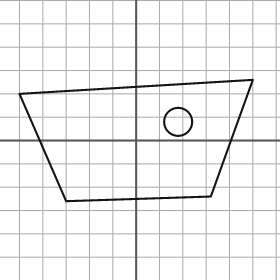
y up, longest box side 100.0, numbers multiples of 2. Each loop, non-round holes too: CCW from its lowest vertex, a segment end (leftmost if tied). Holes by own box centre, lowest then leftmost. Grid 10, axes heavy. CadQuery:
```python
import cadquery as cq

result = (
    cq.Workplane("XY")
    .moveTo(-30.0, -26.0)
    .lineTo(32.0, -24.0)
    .lineTo(50.0, 26.0)
    .lineTo(-50.0, 20.0)
    .close()
    .moveTo(18.0, 8.0)
    .circle(6.0)
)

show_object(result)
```